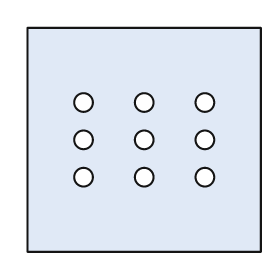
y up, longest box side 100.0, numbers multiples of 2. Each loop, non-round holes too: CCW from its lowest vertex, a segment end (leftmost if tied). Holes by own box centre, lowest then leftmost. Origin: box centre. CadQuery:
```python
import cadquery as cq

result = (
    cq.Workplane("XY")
    .moveTo(-50.0, -48.0)
    .lineTo(50.0, -48.0)
    .lineTo(50.0, 48.0)
    .lineTo(-50.0, 48.0)
    .close()
    .moveTo(-26.0, -16.0)
    .circle(4.0)
    .moveTo(0.0, -16.0)
    .circle(4.0)
    .moveTo(26.0, -16.0)
    .circle(4.0)
    .moveTo(-26.0, 0.0)
    .circle(4.0)
    .moveTo(0.0, 0.0)
    .circle(4.0)
    .moveTo(26.0, 0.0)
    .circle(4.0)
    .moveTo(-26.0, 16.0)
    .circle(4.0)
    .moveTo(0.0, 16.0)
    .circle(4.0)
    .moveTo(26.0, 16.0)
    .circle(4.0)
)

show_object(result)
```